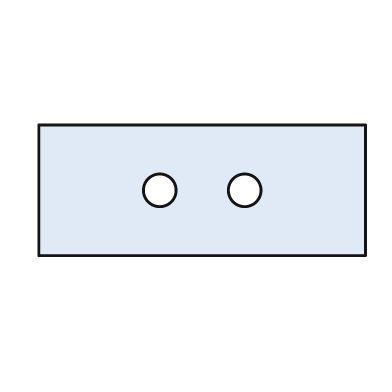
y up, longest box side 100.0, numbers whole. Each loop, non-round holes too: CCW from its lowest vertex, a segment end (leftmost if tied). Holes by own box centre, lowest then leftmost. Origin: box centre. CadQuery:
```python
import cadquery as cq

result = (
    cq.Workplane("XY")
    .moveTo(-50.0, -20.0)
    .lineTo(50.0, -20.0)
    .lineTo(50.0, 20.0)
    .lineTo(-50.0, 20.0)
    .close()
    .moveTo(-13.0, 0.0)
    .circle(5.0)
    .moveTo(13.0, 0.0)
    .circle(5.0)
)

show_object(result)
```